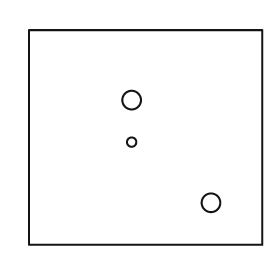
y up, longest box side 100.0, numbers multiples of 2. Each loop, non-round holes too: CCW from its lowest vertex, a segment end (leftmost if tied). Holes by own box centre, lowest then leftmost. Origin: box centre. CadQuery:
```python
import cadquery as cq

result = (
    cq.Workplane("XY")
    .moveTo(-50.0, -46.0)
    .lineTo(50.0, -46.0)
    .lineTo(50.0, 46.0)
    .lineTo(-50.0, 46.0)
    .close()
    .moveTo(28.0, -28.0)
    .circle(4.0)
    .moveTo(-6.0, -2.0)
    .circle(2.0)
    .moveTo(-6.0, 16.0)
    .circle(4.0)
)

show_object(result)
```